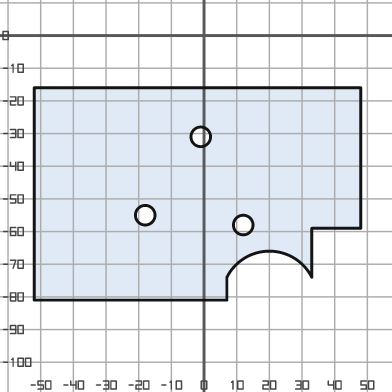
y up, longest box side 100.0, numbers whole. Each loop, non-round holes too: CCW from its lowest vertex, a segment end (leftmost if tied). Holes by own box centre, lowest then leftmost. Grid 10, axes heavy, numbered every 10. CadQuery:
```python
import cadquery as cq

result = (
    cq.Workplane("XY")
    .moveTo(-52.0, -81.0)
    .lineTo(7.0, -81.0)
    .lineTo(7.0, -74.0)
    .threePointArc((20.0, -66.0), (33.0, -74.0))
    .lineTo(33.0, -59.0)
    .lineTo(48.0, -59.0)
    .lineTo(48.0, -16.0)
    .lineTo(-52.0, -16.0)
    .close()
    .moveTo(12.0, -58.0)
    .circle(3.0)
    .moveTo(-18.0, -55.0)
    .circle(3.0)
    .moveTo(-1.0, -31.0)
    .circle(3.0)
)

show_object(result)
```